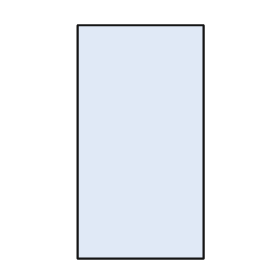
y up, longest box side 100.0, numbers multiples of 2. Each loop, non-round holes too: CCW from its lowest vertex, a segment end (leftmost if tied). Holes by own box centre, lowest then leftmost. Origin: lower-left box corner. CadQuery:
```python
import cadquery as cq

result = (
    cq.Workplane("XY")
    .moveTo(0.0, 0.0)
    .lineTo(54.0, 0.0)
    .lineTo(54.0, 100.0)
    .lineTo(0.0, 100.0)
    .close()
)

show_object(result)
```